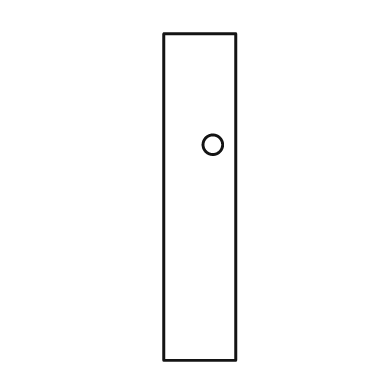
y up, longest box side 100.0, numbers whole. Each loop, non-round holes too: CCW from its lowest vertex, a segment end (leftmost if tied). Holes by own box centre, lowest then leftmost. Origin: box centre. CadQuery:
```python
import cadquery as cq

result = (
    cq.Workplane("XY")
    .moveTo(-11.0, -50.0)
    .lineTo(11.0, -50.0)
    .lineTo(11.0, 50.0)
    .lineTo(-11.0, 50.0)
    .close()
    .moveTo(4.0, 16.0)
    .circle(3.0)
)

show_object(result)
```